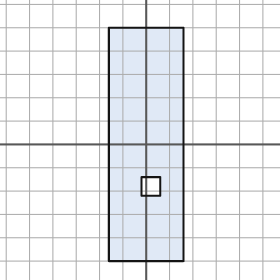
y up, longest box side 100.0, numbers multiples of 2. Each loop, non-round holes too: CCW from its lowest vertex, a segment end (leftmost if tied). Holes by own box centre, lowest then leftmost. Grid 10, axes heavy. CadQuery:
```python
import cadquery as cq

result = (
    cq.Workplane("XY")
    .moveTo(-16.0, -50.0)
    .lineTo(16.0, -50.0)
    .lineTo(16.0, 50.0)
    .lineTo(-16.0, 50.0)
    .close()
    .moveTo(-2.0, -22.0)
    .lineTo(6.0, -22.0)
    .lineTo(6.0, -14.0)
    .lineTo(-2.0, -14.0)
    .close()
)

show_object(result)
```